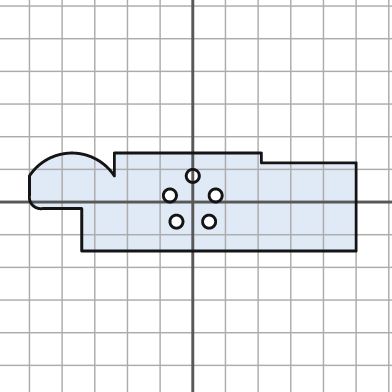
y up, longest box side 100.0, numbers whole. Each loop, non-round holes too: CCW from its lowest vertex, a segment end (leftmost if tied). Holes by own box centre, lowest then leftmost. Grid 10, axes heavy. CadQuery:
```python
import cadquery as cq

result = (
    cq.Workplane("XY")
    .moveTo(-34.0, -15.0)
    .lineTo(50.0, -15.0)
    .lineTo(50.0, 12.0)
    .lineTo(21.0, 12.0)
    .lineTo(21.0, 15.0)
    .lineTo(-24.0, 15.0)
    .lineTo(-24.0, 8.0)
    .threePointArc((-37.0, 15.0), (-50.0, 8.0))
    .lineTo(-50.0, 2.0)
    .threePointArc((-49.0, -1.0), (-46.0, -2.0))
    .lineTo(-34.0, -2.0)
    .close()
    .moveTo(-5.0, -6.0)
    .circle(2.0)
    .moveTo(5.0, -6.0)
    .circle(2.0)
    .moveTo(-7.0, 2.0)
    .circle(2.0)
    .moveTo(7.0, 2.0)
    .circle(2.0)
    .moveTo(0.0, 8.0)
    .circle(2.0)
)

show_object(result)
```